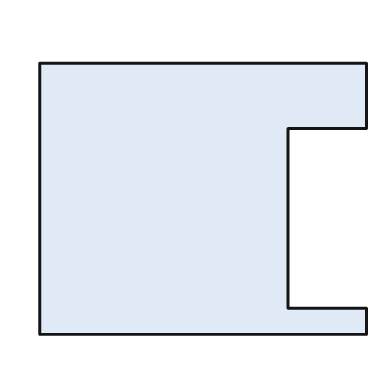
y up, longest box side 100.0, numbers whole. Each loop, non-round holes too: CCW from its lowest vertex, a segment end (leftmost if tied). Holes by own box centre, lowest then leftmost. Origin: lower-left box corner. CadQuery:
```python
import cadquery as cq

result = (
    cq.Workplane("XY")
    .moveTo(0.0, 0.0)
    .lineTo(100.0, 0.0)
    .lineTo(100.0, 8.0)
    .lineTo(76.0, 8.0)
    .lineTo(76.0, 63.0)
    .lineTo(100.0, 63.0)
    .lineTo(100.0, 83.0)
    .lineTo(0.0, 83.0)
    .close()
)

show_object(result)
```